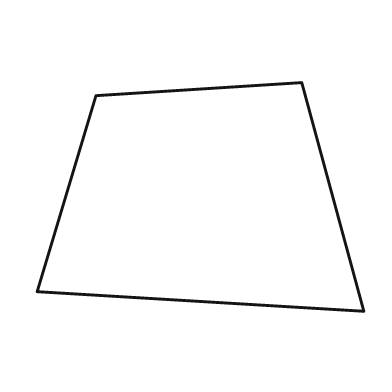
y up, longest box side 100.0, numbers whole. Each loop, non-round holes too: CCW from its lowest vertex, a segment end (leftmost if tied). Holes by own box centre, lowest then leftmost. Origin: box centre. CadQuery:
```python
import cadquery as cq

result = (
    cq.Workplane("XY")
    .moveTo(50.0, -35.0)
    .lineTo(31.0, 35.0)
    .lineTo(-32.0, 31.0)
    .lineTo(-50.0, -29.0)
    .close()
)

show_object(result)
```